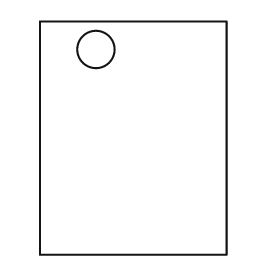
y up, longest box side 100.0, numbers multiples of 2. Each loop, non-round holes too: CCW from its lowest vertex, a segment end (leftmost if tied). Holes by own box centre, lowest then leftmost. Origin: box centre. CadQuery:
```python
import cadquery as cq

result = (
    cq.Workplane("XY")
    .moveTo(-40.0, -50.0)
    .lineTo(40.0, -50.0)
    .lineTo(40.0, 50.0)
    .lineTo(-40.0, 50.0)
    .close()
    .moveTo(-16.0, 38.0)
    .circle(8.0)
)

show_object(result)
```